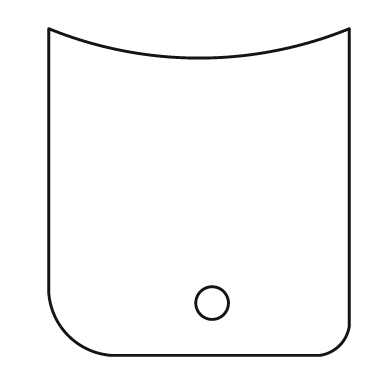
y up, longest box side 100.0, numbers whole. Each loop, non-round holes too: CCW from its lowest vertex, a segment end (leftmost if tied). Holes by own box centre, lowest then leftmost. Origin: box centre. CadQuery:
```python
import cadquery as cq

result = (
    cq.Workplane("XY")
    .moveTo(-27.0, -50.0)
    .lineTo(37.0, -50.0)
    .threePointArc((43.0, -47.0), (46.0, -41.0))
    .lineTo(46.0, 50.0)
    .threePointArc((0.0, 41.0), (-46.0, 50.0))
    .lineTo(-46.0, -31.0)
    .threePointArc((-40.0, -44.0), (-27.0, -50.0))
    .close()
    .moveTo(4.0, -34.0)
    .circle(5.0)
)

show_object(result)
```